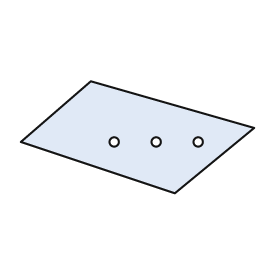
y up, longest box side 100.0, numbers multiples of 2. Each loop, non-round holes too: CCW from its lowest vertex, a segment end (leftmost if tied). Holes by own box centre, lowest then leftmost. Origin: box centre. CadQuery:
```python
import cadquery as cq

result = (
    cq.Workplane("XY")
    .moveTo(16.0, -24.0)
    .lineTo(50.0, 4.0)
    .lineTo(-20.0, 24.0)
    .lineTo(-50.0, -2.0)
    .close()
    .moveTo(-10.0, -2.0)
    .circle(2.0)
    .moveTo(8.0, -2.0)
    .circle(2.0)
    .moveTo(26.0, -2.0)
    .circle(2.0)
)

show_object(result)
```